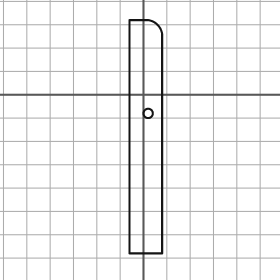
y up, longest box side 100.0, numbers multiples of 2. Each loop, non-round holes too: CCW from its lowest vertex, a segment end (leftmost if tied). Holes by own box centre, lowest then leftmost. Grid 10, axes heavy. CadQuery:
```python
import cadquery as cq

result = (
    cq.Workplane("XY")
    .moveTo(-6.0, -68.0)
    .lineTo(8.0, -68.0)
    .lineTo(8.0, 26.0)
    .threePointArc((6.0, 30.0), (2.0, 32.0))
    .lineTo(-6.0, 32.0)
    .close()
    .moveTo(2.0, -8.0)
    .circle(2.0)
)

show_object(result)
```